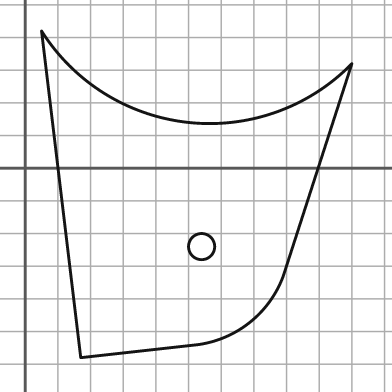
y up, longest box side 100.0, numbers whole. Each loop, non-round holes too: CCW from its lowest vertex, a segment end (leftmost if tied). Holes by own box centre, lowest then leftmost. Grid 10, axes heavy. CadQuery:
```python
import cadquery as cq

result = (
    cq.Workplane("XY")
    .moveTo(17.0, -58.0)
    .lineTo(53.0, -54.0)
    .threePointArc((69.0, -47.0), (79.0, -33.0))
    .lineTo(100.0, 32.0)
    .threePointArc((50.0, 14.0), (5.0, 42.0))
    .close()
    .moveTo(54.0, -24.0)
    .circle(4.0)
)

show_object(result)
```